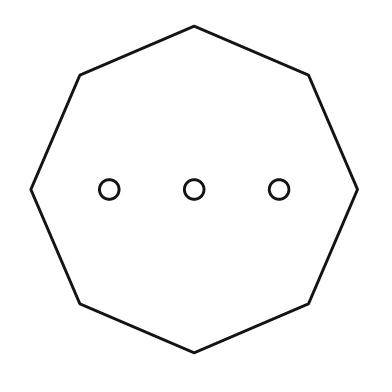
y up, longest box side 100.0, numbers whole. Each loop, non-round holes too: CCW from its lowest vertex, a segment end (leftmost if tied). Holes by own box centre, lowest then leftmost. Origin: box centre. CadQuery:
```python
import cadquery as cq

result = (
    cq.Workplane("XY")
    .moveTo(0.0, -50.0)
    .lineTo(35.0, -35.0)
    .lineTo(50.0, 0.0)
    .lineTo(35.0, 35.0)
    .lineTo(0.0, 50.0)
    .lineTo(-35.0, 35.0)
    .lineTo(-50.0, 0.0)
    .lineTo(-35.0, -35.0)
    .close()
    .moveTo(-26.0, 0.0)
    .circle(3.0)
    .moveTo(0.0, 0.0)
    .circle(3.0)
    .moveTo(26.0, 0.0)
    .circle(3.0)
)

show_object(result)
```